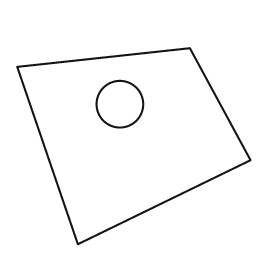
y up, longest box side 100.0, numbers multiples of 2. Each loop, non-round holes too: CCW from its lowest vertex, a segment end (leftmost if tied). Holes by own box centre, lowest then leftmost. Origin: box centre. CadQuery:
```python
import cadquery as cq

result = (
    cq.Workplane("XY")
    .moveTo(-24.0, -42.0)
    .lineTo(50.0, -6.0)
    .lineTo(24.0, 42.0)
    .lineTo(-50.0, 34.0)
    .close()
    .moveTo(-6.0, 18.0)
    .circle(10.0)
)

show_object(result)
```